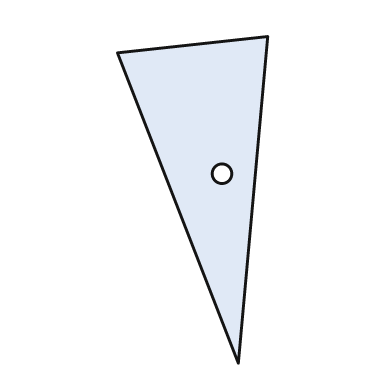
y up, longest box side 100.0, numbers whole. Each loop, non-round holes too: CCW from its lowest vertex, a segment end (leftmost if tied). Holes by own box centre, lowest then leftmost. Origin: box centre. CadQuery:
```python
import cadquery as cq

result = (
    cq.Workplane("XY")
    .moveTo(14.0, -50.0)
    .lineTo(23.0, 50.0)
    .lineTo(-23.0, 45.0)
    .close()
    .moveTo(9.0, 8.0)
    .circle(3.0)
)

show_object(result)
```